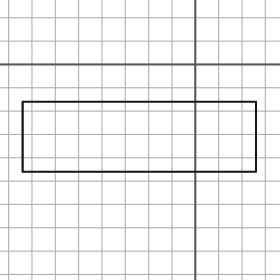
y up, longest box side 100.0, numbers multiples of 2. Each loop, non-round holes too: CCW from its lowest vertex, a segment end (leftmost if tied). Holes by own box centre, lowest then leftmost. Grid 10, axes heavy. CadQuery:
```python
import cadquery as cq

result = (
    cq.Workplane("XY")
    .moveTo(-74.0, -46.0)
    .lineTo(26.0, -46.0)
    .lineTo(26.0, -16.0)
    .lineTo(-74.0, -16.0)
    .close()
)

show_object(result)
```